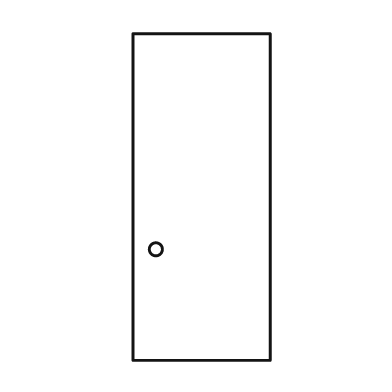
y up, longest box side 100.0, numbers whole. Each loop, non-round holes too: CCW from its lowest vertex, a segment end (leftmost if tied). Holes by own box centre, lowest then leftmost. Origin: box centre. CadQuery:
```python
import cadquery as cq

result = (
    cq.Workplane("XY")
    .moveTo(-21.0, -50.0)
    .lineTo(21.0, -50.0)
    .lineTo(21.0, 50.0)
    .lineTo(-21.0, 50.0)
    .close()
    .moveTo(-14.0, -16.0)
    .circle(2.0)
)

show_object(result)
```